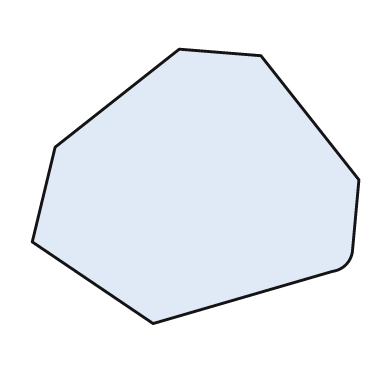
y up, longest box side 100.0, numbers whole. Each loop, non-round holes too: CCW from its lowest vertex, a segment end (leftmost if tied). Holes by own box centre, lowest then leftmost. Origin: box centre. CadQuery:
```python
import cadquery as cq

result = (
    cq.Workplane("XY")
    .moveTo(-13.0, -42.0)
    .lineTo(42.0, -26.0)
    .threePointArc((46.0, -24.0), (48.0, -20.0))
    .lineTo(50.0, 2.0)
    .lineTo(20.0, 40.0)
    .lineTo(-5.0, 42.0)
    .lineTo(-43.0, 12.0)
    .lineTo(-50.0, -17.0)
    .close()
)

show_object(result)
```